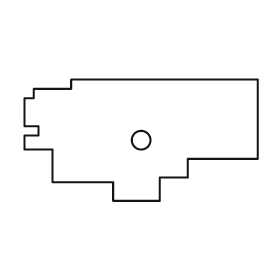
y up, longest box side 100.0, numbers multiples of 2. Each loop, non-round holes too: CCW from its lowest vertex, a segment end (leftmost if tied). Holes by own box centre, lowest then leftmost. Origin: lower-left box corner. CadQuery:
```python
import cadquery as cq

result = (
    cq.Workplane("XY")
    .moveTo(38.0, 0.0)
    .lineTo(58.0, 0.0)
    .lineTo(58.0, 10.0)
    .lineTo(70.0, 10.0)
    .lineTo(70.0, 18.0)
    .lineTo(100.0, 18.0)
    .lineTo(100.0, 52.0)
    .lineTo(20.0, 52.0)
    .lineTo(20.0, 48.0)
    .lineTo(4.0, 48.0)
    .lineTo(4.0, 44.0)
    .lineTo(0.0, 44.0)
    .lineTo(0.0, 32.0)
    .lineTo(6.0, 32.0)
    .lineTo(6.0, 28.0)
    .lineTo(0.0, 28.0)
    .lineTo(0.0, 22.0)
    .lineTo(12.0, 22.0)
    .lineTo(12.0, 8.0)
    .lineTo(38.0, 8.0)
    .close()
    .moveTo(50.0, 26.0)
    .circle(4.0)
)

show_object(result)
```